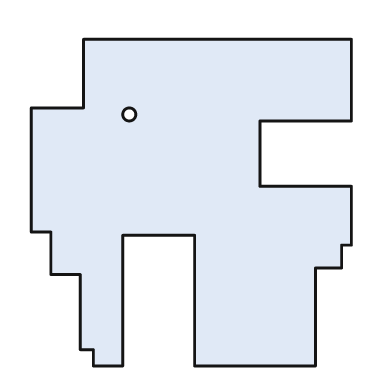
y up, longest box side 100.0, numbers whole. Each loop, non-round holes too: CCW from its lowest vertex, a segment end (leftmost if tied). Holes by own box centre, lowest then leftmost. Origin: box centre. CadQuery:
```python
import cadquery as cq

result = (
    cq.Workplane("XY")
    .moveTo(-30.0, -50.0)
    .lineTo(-21.0, -50.0)
    .lineTo(-21.0, -10.0)
    .lineTo(1.0, -10.0)
    .lineTo(1.0, -50.0)
    .lineTo(38.0, -50.0)
    .lineTo(38.0, -20.0)
    .lineTo(46.0, -20.0)
    .lineTo(46.0, -13.0)
    .lineTo(49.0, -13.0)
    .lineTo(49.0, 5.0)
    .lineTo(21.0, 5.0)
    .lineTo(21.0, 25.0)
    .lineTo(49.0, 25.0)
    .lineTo(49.0, 50.0)
    .lineTo(-33.0, 50.0)
    .lineTo(-33.0, 29.0)
    .lineTo(-49.0, 29.0)
    .lineTo(-49.0, -9.0)
    .lineTo(-43.0, -9.0)
    .lineTo(-43.0, -22.0)
    .lineTo(-34.0, -22.0)
    .lineTo(-34.0, -45.0)
    .lineTo(-30.0, -45.0)
    .close()
    .moveTo(-19.0, 27.0)
    .circle(2.0)
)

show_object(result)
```